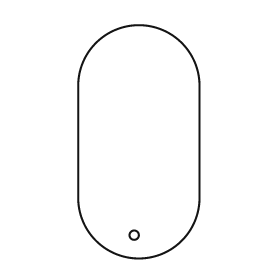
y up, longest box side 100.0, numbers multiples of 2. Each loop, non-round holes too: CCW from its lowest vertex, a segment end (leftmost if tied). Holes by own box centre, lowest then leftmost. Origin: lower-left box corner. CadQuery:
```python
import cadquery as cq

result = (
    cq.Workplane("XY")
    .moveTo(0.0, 26.0)
    .threePointArc((26.0, 0.0), (52.0, 26.0))
    .lineTo(52.0, 74.0)
    .threePointArc((26.0, 100.0), (0.0, 74.0))
    .close()
    .moveTo(24.0, 10.0)
    .circle(2.0)
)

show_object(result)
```